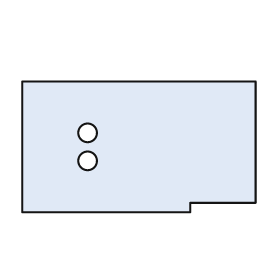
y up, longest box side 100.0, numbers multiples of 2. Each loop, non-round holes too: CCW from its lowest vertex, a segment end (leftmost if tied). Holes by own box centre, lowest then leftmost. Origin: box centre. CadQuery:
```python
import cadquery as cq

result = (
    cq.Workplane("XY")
    .moveTo(-50.0, -28.0)
    .lineTo(22.0, -28.0)
    .lineTo(22.0, -24.0)
    .lineTo(50.0, -24.0)
    .lineTo(50.0, 28.0)
    .lineTo(-50.0, 28.0)
    .close()
    .moveTo(-22.0, -6.0)
    .circle(4.0)
    .moveTo(-22.0, 6.0)
    .circle(4.0)
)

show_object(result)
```